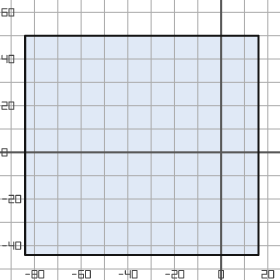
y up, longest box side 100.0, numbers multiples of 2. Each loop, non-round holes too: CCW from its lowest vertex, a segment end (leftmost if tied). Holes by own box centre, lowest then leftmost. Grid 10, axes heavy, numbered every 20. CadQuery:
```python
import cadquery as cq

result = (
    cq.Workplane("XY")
    .moveTo(-84.0, -44.0)
    .lineTo(16.0, -44.0)
    .lineTo(16.0, 50.0)
    .lineTo(-84.0, 50.0)
    .close()
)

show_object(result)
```